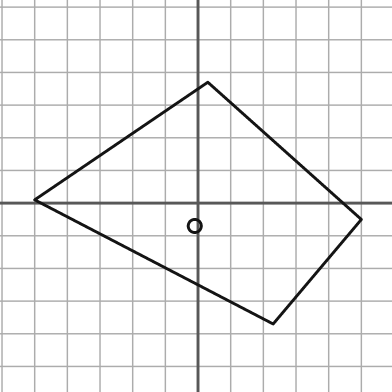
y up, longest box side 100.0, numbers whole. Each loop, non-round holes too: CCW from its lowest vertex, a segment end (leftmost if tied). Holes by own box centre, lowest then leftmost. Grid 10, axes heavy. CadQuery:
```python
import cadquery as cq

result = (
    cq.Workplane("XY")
    .moveTo(23.0, -37.0)
    .lineTo(50.0, -5.0)
    .lineTo(3.0, 37.0)
    .lineTo(-50.0, 1.0)
    .close()
    .moveTo(-1.0, -7.0)
    .circle(2.0)
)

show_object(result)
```